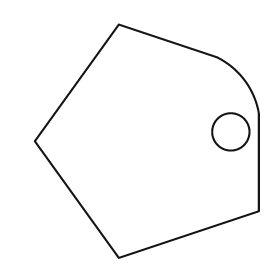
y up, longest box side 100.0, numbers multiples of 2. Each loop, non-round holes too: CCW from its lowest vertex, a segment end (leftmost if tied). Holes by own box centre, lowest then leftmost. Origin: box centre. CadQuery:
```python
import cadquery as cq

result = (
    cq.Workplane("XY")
    .moveTo(-12.0, -50.0)
    .lineTo(48.0, -30.0)
    .lineTo(48.0, 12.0)
    .threePointArc((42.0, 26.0), (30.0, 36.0))
    .lineTo(-12.0, 50.0)
    .lineTo(-48.0, 0.0)
    .close()
    .moveTo(36.0, 4.0)
    .circle(8.0)
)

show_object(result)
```